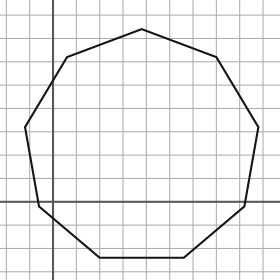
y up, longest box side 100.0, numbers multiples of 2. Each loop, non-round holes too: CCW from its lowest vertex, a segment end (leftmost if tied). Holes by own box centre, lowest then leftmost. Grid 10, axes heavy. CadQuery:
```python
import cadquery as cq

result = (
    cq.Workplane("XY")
    .moveTo(20.0, -24.0)
    .lineTo(56.0, -24.0)
    .lineTo(82.0, -2.0)
    .lineTo(88.0, 32.0)
    .lineTo(70.0, 62.0)
    .lineTo(38.0, 74.0)
    .lineTo(6.0, 62.0)
    .lineTo(-12.0, 32.0)
    .lineTo(-6.0, -2.0)
    .close()
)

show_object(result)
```